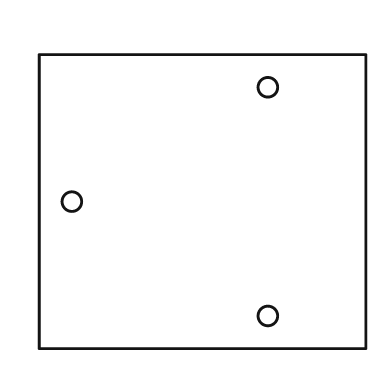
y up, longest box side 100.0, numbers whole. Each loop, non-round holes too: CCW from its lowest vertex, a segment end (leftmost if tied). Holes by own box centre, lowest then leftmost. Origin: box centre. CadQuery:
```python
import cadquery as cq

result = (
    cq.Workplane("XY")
    .moveTo(-50.0, -45.0)
    .lineTo(50.0, -45.0)
    .lineTo(50.0, 45.0)
    .lineTo(-50.0, 45.0)
    .close()
    .moveTo(20.0, -35.0)
    .circle(3.0)
    .moveTo(-40.0, 0.0)
    .circle(3.0)
    .moveTo(20.0, 35.0)
    .circle(3.0)
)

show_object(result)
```